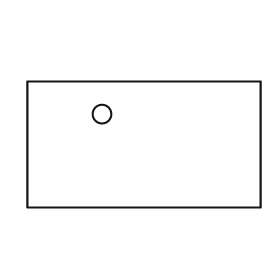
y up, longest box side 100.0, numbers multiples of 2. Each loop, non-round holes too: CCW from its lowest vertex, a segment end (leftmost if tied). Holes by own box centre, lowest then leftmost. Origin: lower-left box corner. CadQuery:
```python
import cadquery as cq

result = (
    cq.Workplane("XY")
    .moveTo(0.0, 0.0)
    .lineTo(100.0, 0.0)
    .lineTo(100.0, 54.0)
    .lineTo(0.0, 54.0)
    .close()
    .moveTo(32.0, 40.0)
    .circle(4.0)
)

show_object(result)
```